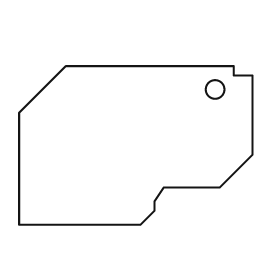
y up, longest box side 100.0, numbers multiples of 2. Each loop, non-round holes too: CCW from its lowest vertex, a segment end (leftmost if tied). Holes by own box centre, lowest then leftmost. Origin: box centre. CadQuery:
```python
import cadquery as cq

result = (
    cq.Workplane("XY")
    .moveTo(-50.0, -34.0)
    .lineTo(2.0, -34.0)
    .lineTo(8.0, -28.0)
    .lineTo(8.0, -24.0)
    .lineTo(12.0, -18.0)
    .lineTo(36.0, -18.0)
    .lineTo(50.0, -4.0)
    .lineTo(50.0, 30.0)
    .lineTo(42.0, 30.0)
    .lineTo(42.0, 34.0)
    .lineTo(-30.0, 34.0)
    .lineTo(-50.0, 14.0)
    .close()
    .moveTo(34.0, 24.0)
    .circle(4.0)
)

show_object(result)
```